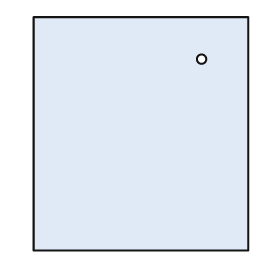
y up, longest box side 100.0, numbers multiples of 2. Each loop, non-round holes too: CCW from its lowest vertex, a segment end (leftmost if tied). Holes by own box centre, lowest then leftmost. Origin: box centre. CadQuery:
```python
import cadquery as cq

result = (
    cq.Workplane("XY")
    .moveTo(-46.0, -50.0)
    .lineTo(46.0, -50.0)
    .lineTo(46.0, 50.0)
    .lineTo(-46.0, 50.0)
    .close()
    .moveTo(26.0, 32.0)
    .circle(2.0)
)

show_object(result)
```